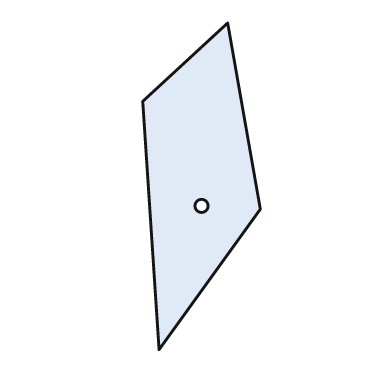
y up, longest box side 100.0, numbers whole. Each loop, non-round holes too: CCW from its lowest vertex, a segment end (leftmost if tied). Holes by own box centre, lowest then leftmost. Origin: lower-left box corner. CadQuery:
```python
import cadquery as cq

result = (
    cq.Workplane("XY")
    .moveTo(5.0, 0.0)
    .lineTo(36.0, 43.0)
    .lineTo(26.0, 100.0)
    .lineTo(0.0, 76.0)
    .close()
    .moveTo(18.0, 44.0)
    .circle(2.0)
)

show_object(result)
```